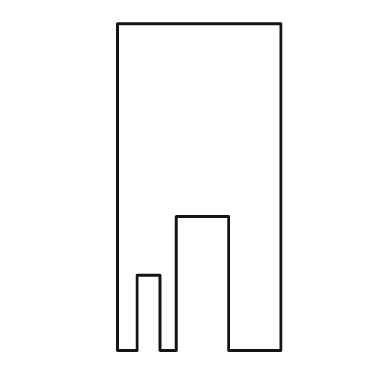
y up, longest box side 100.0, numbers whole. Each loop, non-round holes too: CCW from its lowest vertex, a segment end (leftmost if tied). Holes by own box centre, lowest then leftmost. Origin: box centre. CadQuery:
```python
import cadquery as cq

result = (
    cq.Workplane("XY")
    .moveTo(-25.0, -50.0)
    .lineTo(-19.0, -50.0)
    .lineTo(-19.0, -27.0)
    .lineTo(-12.0, -27.0)
    .lineTo(-12.0, -50.0)
    .lineTo(-7.0, -50.0)
    .lineTo(-7.0, -9.0)
    .lineTo(9.0, -9.0)
    .lineTo(9.0, -50.0)
    .lineTo(25.0, -50.0)
    .lineTo(25.0, 50.0)
    .lineTo(-25.0, 50.0)
    .close()
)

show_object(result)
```